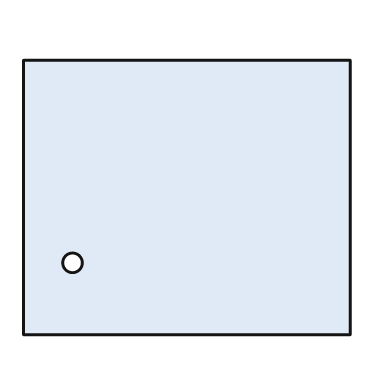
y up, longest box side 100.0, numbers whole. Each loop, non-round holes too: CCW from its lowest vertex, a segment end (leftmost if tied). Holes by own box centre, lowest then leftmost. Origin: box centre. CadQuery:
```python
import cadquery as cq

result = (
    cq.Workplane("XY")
    .moveTo(-50.0, -42.0)
    .lineTo(50.0, -42.0)
    .lineTo(50.0, 42.0)
    .lineTo(-50.0, 42.0)
    .close()
    .moveTo(-35.0, -20.0)
    .circle(3.0)
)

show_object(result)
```